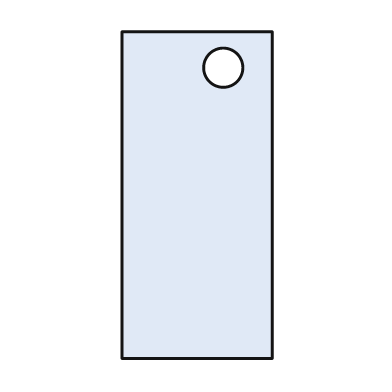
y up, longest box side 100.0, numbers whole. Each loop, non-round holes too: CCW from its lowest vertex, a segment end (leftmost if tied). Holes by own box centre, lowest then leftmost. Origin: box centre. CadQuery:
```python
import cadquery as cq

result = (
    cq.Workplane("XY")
    .moveTo(-23.0, -50.0)
    .lineTo(23.0, -50.0)
    .lineTo(23.0, 50.0)
    .lineTo(-23.0, 50.0)
    .close()
    .moveTo(8.0, 39.0)
    .circle(6.0)
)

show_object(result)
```